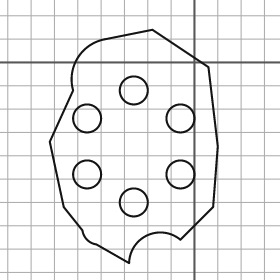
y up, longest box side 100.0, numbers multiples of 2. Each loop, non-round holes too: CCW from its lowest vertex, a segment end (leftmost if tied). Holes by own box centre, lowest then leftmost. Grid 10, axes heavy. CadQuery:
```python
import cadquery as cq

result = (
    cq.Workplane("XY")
    .moveTo(-28.0, -86.0)
    .threePointArc((-20.0, -74.0), (-6.0, -76.0))
    .lineTo(8.0, -62.0)
    .lineTo(10.0, -36.0)
    .lineTo(6.0, -2.0)
    .lineTo(-18.0, 14.0)
    .lineTo(-38.0, 10.0)
    .threePointArc((-50.0, 2.0), (-52.0, -12.0))
    .lineTo(-62.0, -34.0)
    .lineTo(-56.0, -62.0)
    .lineTo(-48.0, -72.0)
    .threePointArc((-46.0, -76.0), (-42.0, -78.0))
    .close()
    .moveTo(-26.0, -60.0)
    .circle(6.0)
    .moveTo(-46.0, -48.0)
    .circle(6.0)
    .moveTo(-6.0, -48.0)
    .circle(6.0)
    .moveTo(-46.0, -24.0)
    .circle(6.0)
    .moveTo(-6.0, -24.0)
    .circle(6.0)
    .moveTo(-26.0, -12.0)
    .circle(6.0)
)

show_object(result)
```